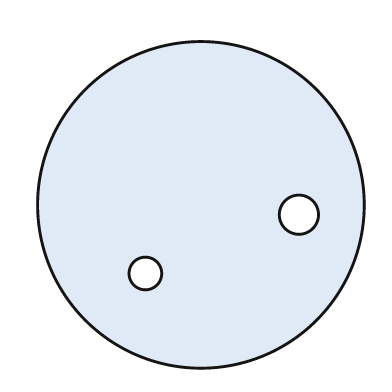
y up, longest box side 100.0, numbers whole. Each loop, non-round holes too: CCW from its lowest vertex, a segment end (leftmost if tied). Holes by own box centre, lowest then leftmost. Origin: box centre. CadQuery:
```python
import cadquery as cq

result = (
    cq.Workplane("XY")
    .moveTo(0.0, 0.0)
    .circle(50.0)
    .moveTo(-17.0, -21.0)
    .circle(5.0)
    .moveTo(30.0, -3.0)
    .circle(6.0)
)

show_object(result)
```